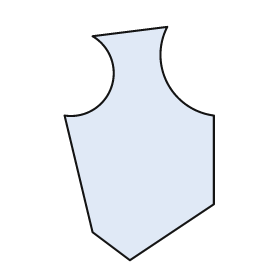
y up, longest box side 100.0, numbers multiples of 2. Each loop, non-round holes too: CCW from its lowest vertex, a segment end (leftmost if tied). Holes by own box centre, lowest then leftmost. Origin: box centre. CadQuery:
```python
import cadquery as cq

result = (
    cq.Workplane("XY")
    .moveTo(-4.0, -50.0)
    .lineTo(32.0, -26.0)
    .lineTo(32.0, 12.0)
    .threePointArc((12.0, 26.0), (12.0, 50.0))
    .lineTo(-20.0, 46.0)
    .threePointArc((-12.0, 24.0), (-32.0, 12.0))
    .lineTo(-20.0, -38.0)
    .close()
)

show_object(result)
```